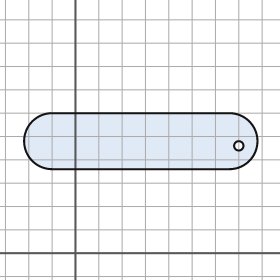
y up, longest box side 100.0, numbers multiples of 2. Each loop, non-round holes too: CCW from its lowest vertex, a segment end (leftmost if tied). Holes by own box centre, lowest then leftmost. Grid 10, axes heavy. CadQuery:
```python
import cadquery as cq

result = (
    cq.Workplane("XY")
    .moveTo(-10.0, 36.0)
    .lineTo(66.0, 36.0)
    .threePointArc((78.0, 48.0), (66.0, 60.0))
    .lineTo(-10.0, 60.0)
    .threePointArc((-22.0, 48.0), (-10.0, 36.0))
    .close()
    .moveTo(70.0, 46.0)
    .circle(2.0)
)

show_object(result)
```